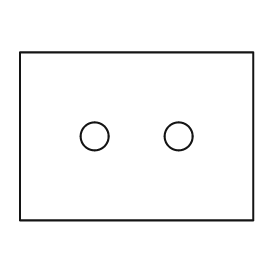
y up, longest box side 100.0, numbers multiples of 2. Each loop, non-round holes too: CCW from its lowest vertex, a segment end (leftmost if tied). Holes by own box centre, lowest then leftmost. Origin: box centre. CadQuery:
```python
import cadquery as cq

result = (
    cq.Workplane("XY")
    .moveTo(-50.0, -36.0)
    .lineTo(50.0, -36.0)
    .lineTo(50.0, 36.0)
    .lineTo(-50.0, 36.0)
    .close()
    .moveTo(-18.0, 0.0)
    .circle(6.0)
    .moveTo(18.0, 0.0)
    .circle(6.0)
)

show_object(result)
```